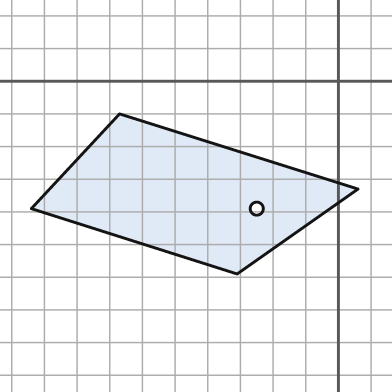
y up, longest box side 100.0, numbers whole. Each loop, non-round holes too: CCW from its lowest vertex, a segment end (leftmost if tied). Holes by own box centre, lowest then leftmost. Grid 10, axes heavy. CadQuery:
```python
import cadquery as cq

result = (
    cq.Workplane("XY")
    .moveTo(-31.0, -59.0)
    .lineTo(6.0, -33.0)
    .lineTo(-67.0, -10.0)
    .lineTo(-94.0, -39.0)
    .close()
    .moveTo(-25.0, -39.0)
    .circle(2.0)
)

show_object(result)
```